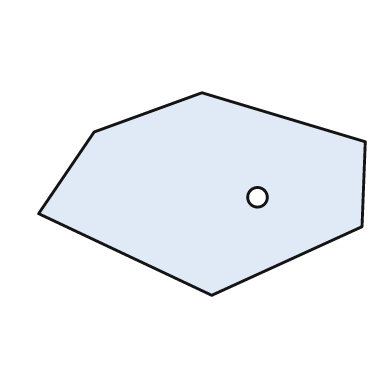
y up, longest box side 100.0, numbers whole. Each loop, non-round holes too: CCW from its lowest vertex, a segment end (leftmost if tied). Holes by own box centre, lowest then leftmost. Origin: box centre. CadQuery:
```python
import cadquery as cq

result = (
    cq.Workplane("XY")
    .moveTo(3.0, -31.0)
    .lineTo(49.0, -10.0)
    .lineTo(50.0, 16.0)
    .lineTo(0.0, 31.0)
    .lineTo(-33.0, 19.0)
    .lineTo(-50.0, -6.0)
    .close()
    .moveTo(17.0, -1.0)
    .circle(3.0)
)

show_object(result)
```